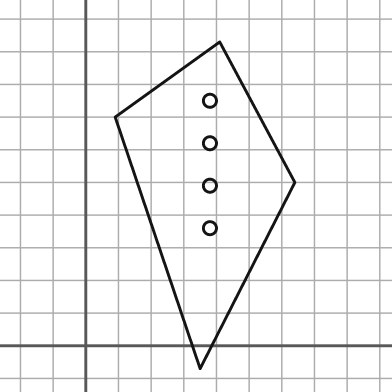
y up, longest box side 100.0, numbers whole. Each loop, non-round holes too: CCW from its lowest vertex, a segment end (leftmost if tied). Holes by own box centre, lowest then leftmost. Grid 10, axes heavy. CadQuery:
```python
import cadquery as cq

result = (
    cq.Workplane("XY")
    .moveTo(35.0, -7.0)
    .lineTo(64.0, 50.0)
    .lineTo(41.0, 93.0)
    .lineTo(9.0, 70.0)
    .close()
    .moveTo(38.0, 36.0)
    .circle(2.0)
    .moveTo(38.0, 49.0)
    .circle(2.0)
    .moveTo(38.0, 62.0)
    .circle(2.0)
    .moveTo(38.0, 75.0)
    .circle(2.0)
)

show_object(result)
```